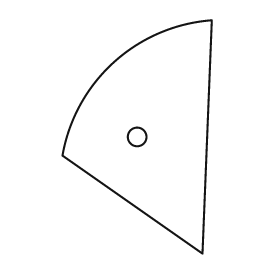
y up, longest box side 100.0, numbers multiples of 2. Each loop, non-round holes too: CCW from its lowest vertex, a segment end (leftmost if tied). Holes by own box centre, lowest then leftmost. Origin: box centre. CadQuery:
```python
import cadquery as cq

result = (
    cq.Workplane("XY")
    .moveTo(28.0, -50.0)
    .lineTo(32.0, 50.0)
    .threePointArc((-10.0, 32.0), (-32.0, -8.0))
    .close()
    .moveTo(0.0, 0.0)
    .circle(4.0)
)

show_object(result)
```